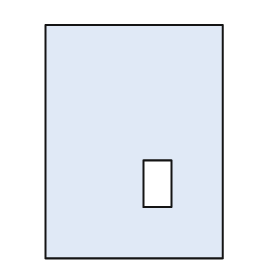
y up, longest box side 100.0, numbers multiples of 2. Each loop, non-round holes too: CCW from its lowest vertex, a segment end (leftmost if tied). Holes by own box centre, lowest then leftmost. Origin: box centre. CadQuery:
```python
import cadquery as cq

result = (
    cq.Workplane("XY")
    .moveTo(-38.0, -50.0)
    .lineTo(38.0, -50.0)
    .lineTo(38.0, 50.0)
    .lineTo(-38.0, 50.0)
    .close()
    .moveTo(4.0, -28.0)
    .lineTo(16.0, -28.0)
    .lineTo(16.0, -8.0)
    .lineTo(4.0, -8.0)
    .close()
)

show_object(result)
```